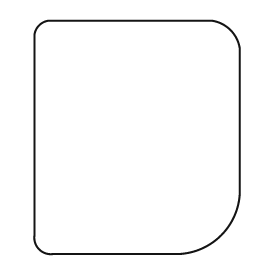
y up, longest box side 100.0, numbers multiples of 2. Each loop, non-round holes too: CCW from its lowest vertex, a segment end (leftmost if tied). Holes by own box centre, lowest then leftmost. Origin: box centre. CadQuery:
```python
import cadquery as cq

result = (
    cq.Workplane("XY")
    .moveTo(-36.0, -50.0)
    .lineTo(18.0, -50.0)
    .threePointArc((36.0, -42.0), (44.0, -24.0))
    .lineTo(44.0, 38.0)
    .threePointArc((40.0, 46.0), (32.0, 50.0))
    .lineTo(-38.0, 50.0)
    .threePointArc((-42.0, 48.0), (-44.0, 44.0))
    .lineTo(-44.0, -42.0)
    .threePointArc((-42.0, -48.0), (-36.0, -50.0))
    .close()
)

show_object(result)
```